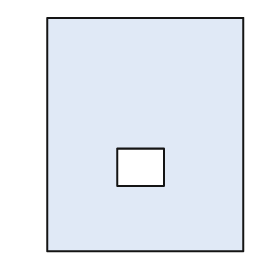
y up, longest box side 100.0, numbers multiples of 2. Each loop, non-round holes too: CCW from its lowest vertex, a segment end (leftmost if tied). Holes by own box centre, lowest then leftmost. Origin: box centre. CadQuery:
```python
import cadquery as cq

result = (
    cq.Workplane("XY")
    .moveTo(-42.0, -50.0)
    .lineTo(42.0, -50.0)
    .lineTo(42.0, 50.0)
    .lineTo(-42.0, 50.0)
    .close()
    .moveTo(-12.0, -22.0)
    .lineTo(8.0, -22.0)
    .lineTo(8.0, -6.0)
    .lineTo(-12.0, -6.0)
    .close()
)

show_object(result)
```